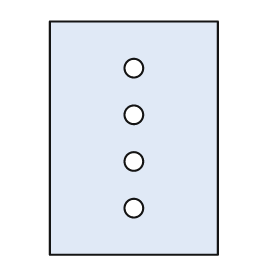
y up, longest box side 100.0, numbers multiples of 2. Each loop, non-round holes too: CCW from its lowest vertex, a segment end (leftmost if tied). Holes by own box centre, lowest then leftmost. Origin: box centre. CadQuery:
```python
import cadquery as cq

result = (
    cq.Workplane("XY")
    .moveTo(-36.0, -50.0)
    .lineTo(36.0, -50.0)
    .lineTo(36.0, 50.0)
    .lineTo(-36.0, 50.0)
    .close()
    .moveTo(0.0, -30.0)
    .circle(4.0)
    .moveTo(0.0, -10.0)
    .circle(4.0)
    .moveTo(0.0, 10.0)
    .circle(4.0)
    .moveTo(0.0, 30.0)
    .circle(4.0)
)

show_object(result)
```